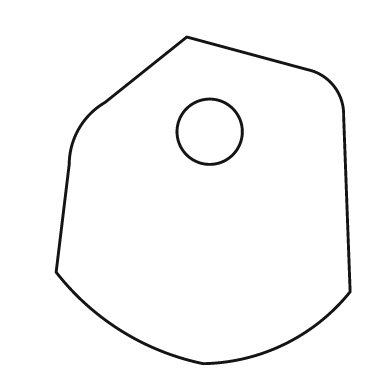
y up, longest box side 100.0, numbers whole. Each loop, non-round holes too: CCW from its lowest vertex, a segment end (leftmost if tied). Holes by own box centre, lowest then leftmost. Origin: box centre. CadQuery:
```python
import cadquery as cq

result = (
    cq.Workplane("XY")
    .moveTo(0.0, -50.0)
    .threePointArc((25.0, -44.0), (45.0, -28.0))
    .lineTo(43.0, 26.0)
    .threePointArc((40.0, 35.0), (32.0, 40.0))
    .lineTo(-5.0, 50.0)
    .lineTo(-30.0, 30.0)
    .threePointArc((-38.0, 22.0), (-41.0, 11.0))
    .lineTo(-45.0, -22.0)
    .threePointArc((-25.0, -40.0), (0.0, -50.0))
    .close()
    .moveTo(2.0, 21.0)
    .circle(10.0)
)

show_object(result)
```